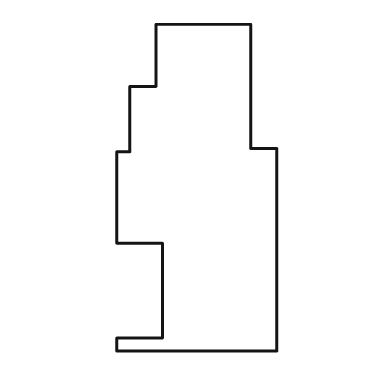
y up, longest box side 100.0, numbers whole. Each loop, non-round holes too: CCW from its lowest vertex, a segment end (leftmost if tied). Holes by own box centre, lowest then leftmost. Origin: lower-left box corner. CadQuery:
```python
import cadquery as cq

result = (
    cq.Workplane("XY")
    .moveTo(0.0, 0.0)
    .lineTo(49.0, 0.0)
    .lineTo(49.0, 62.0)
    .lineTo(41.0, 62.0)
    .lineTo(41.0, 100.0)
    .lineTo(12.0, 100.0)
    .lineTo(12.0, 81.0)
    .lineTo(4.0, 81.0)
    .lineTo(4.0, 61.0)
    .lineTo(0.0, 61.0)
    .lineTo(0.0, 33.0)
    .lineTo(14.0, 33.0)
    .lineTo(14.0, 4.0)
    .lineTo(0.0, 4.0)
    .close()
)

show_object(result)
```